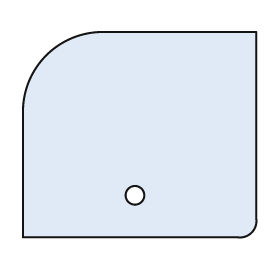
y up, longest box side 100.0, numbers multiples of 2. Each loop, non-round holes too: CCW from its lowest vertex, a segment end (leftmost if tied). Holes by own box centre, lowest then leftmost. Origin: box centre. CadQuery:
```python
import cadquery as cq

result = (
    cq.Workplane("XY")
    .moveTo(-50.0, -44.0)
    .lineTo(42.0, -44.0)
    .threePointArc((48.0, -42.0), (50.0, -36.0))
    .lineTo(50.0, 44.0)
    .lineTo(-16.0, 44.0)
    .threePointArc((-40.0, 34.0), (-50.0, 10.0))
    .close()
    .moveTo(-2.0, -26.0)
    .circle(4.0)
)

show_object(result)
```